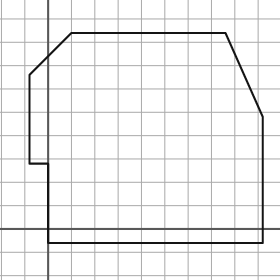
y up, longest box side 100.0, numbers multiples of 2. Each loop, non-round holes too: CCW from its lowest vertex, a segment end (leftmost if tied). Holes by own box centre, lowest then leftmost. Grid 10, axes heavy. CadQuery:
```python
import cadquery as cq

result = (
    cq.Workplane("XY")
    .moveTo(0.0, -6.0)
    .lineTo(92.0, -6.0)
    .lineTo(92.0, 48.0)
    .lineTo(76.0, 84.0)
    .lineTo(10.0, 84.0)
    .lineTo(-8.0, 66.0)
    .lineTo(-8.0, 28.0)
    .lineTo(0.0, 28.0)
    .close()
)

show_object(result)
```